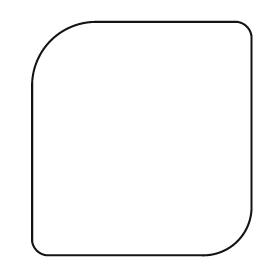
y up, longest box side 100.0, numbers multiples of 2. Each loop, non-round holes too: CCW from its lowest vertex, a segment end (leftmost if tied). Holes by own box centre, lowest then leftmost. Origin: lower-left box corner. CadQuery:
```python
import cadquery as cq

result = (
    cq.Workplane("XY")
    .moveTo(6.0, 0.0)
    .lineTo(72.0, 0.0)
    .threePointArc((88.0, 6.0), (94.0, 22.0))
    .lineTo(94.0, 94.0)
    .threePointArc((92.0, 98.0), (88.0, 100.0))
    .lineTo(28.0, 100.0)
    .threePointArc((8.0, 92.0), (0.0, 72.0))
    .lineTo(0.0, 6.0)
    .threePointArc((2.0, 2.0), (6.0, 0.0))
    .close()
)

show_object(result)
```